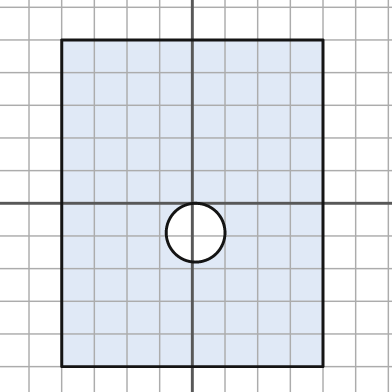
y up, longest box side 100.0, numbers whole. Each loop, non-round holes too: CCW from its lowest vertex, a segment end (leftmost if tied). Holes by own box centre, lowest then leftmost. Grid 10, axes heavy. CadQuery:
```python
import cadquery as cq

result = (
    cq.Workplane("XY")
    .moveTo(-40.0, -50.0)
    .lineTo(40.0, -50.0)
    .lineTo(40.0, 50.0)
    .lineTo(-40.0, 50.0)
    .close()
    .moveTo(1.0, -9.0)
    .circle(9.0)
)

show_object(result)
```